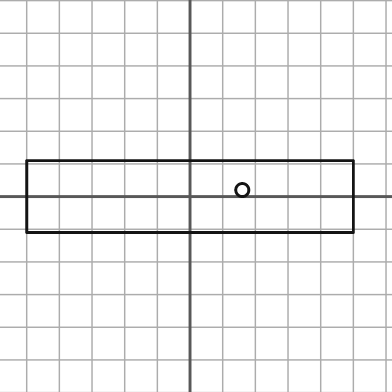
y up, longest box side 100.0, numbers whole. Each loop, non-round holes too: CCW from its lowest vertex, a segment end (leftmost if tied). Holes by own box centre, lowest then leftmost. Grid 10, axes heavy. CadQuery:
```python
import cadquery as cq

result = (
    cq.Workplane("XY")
    .moveTo(-50.0, -11.0)
    .lineTo(50.0, -11.0)
    .lineTo(50.0, 11.0)
    .lineTo(-50.0, 11.0)
    .close()
    .moveTo(16.0, 2.0)
    .circle(2.0)
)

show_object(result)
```